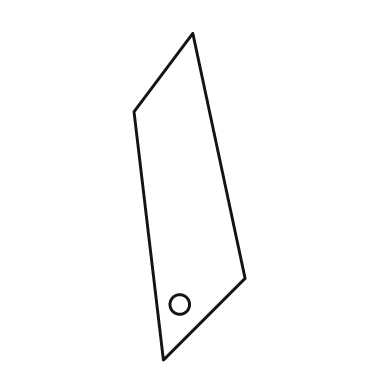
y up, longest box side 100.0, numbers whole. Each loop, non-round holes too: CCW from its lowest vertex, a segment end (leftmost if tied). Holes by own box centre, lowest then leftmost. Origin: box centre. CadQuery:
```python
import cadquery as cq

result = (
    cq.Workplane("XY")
    .moveTo(-8.0, -50.0)
    .lineTo(17.0, -25.0)
    .lineTo(1.0, 50.0)
    .lineTo(-17.0, 26.0)
    .close()
    .moveTo(-3.0, -33.0)
    .circle(3.0)
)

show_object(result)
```